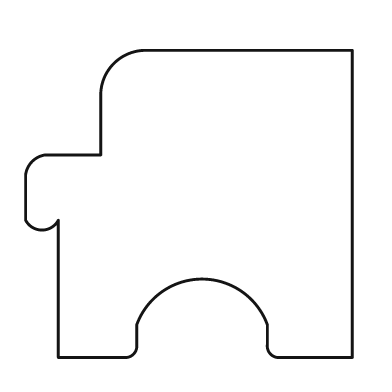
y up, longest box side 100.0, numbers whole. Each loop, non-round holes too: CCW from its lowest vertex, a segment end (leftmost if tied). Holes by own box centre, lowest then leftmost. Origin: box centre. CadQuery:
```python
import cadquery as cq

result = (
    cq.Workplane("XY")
    .moveTo(-40.0, -47.0)
    .lineTo(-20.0, -47.0)
    .threePointArc((-17.0, -46.0), (-16.0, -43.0))
    .lineTo(-16.0, -37.0)
    .threePointArc((4.0, -23.0), (24.0, -37.0))
    .lineTo(24.0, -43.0)
    .threePointArc((25.0, -46.0), (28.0, -47.0))
    .lineTo(50.0, -47.0)
    .lineTo(50.0, 47.0)
    .lineTo(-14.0, 47.0)
    .threePointArc((-23.0, 43.0), (-27.0, 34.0))
    .lineTo(-27.0, 15.0)
    .lineTo(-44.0, 15.0)
    .threePointArc((-48.0, 13.0), (-50.0, 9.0))
    .lineTo(-50.0, -5.0)
    .threePointArc((-45.0, -8.0), (-40.0, -5.0))
    .close()
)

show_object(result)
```